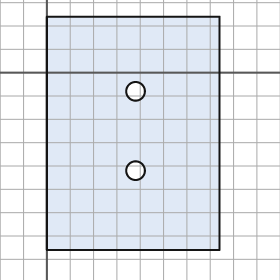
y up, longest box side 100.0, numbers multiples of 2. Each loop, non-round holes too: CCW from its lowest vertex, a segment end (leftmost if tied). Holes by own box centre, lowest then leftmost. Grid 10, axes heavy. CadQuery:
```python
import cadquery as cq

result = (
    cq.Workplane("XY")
    .moveTo(0.0, -76.0)
    .lineTo(74.0, -76.0)
    .lineTo(74.0, 24.0)
    .lineTo(0.0, 24.0)
    .close()
    .moveTo(38.0, -42.0)
    .circle(4.0)
    .moveTo(38.0, -8.0)
    .circle(4.0)
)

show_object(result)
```